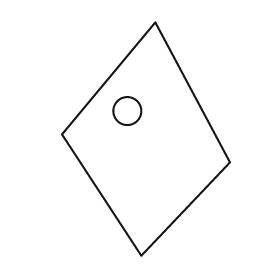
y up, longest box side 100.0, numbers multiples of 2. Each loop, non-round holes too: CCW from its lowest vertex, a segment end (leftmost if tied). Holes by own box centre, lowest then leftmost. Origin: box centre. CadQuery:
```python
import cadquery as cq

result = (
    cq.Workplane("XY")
    .moveTo(-2.0, -50.0)
    .lineTo(36.0, -10.0)
    .lineTo(4.0, 50.0)
    .lineTo(-36.0, 2.0)
    .close()
    .moveTo(-8.0, 12.0)
    .circle(6.0)
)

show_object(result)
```